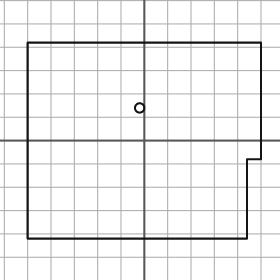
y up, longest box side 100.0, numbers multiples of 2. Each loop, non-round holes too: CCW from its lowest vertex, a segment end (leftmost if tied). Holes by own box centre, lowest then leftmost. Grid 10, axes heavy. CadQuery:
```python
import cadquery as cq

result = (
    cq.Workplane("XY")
    .moveTo(-50.0, -42.0)
    .lineTo(44.0, -42.0)
    .lineTo(44.0, -8.0)
    .lineTo(50.0, -8.0)
    .lineTo(50.0, 42.0)
    .lineTo(-50.0, 42.0)
    .close()
    .moveTo(-2.0, 14.0)
    .circle(2.0)
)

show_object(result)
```